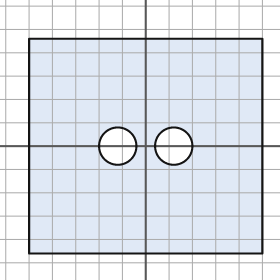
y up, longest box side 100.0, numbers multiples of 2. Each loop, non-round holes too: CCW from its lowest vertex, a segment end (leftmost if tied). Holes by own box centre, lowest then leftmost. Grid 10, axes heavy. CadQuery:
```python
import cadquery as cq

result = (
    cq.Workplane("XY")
    .moveTo(-50.0, -46.0)
    .lineTo(50.0, -46.0)
    .lineTo(50.0, 46.0)
    .lineTo(-50.0, 46.0)
    .close()
    .moveTo(-12.0, 0.0)
    .circle(8.0)
    .moveTo(12.0, 0.0)
    .circle(8.0)
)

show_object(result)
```